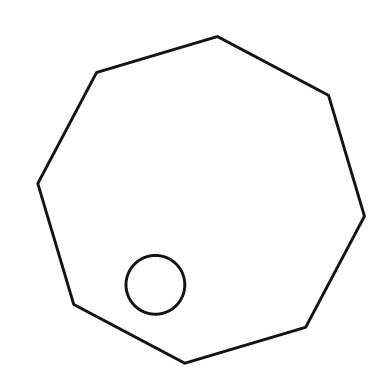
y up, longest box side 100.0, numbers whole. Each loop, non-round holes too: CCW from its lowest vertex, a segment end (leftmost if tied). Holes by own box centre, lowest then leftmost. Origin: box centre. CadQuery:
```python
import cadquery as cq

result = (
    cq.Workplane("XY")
    .moveTo(-5.0, -50.0)
    .lineTo(32.0, -39.0)
    .lineTo(50.0, -5.0)
    .lineTo(39.0, 32.0)
    .lineTo(5.0, 50.0)
    .lineTo(-32.0, 39.0)
    .lineTo(-50.0, 5.0)
    .lineTo(-39.0, -32.0)
    .close()
    .moveTo(-14.0, -26.0)
    .circle(9.0)
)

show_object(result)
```